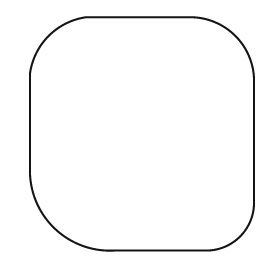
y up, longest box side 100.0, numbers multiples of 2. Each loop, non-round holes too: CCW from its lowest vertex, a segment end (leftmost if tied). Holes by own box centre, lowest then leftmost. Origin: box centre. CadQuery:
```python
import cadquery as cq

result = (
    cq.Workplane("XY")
    .moveTo(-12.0, -50.0)
    .lineTo(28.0, -50.0)
    .threePointArc((42.0, -44.0), (48.0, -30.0))
    .lineTo(48.0, 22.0)
    .threePointArc((40.0, 42.0), (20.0, 50.0))
    .lineTo(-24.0, 50.0)
    .threePointArc((-40.0, 42.0), (-48.0, 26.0))
    .lineTo(-48.0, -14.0)
    .threePointArc((-38.0, -40.0), (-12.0, -50.0))
    .close()
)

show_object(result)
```